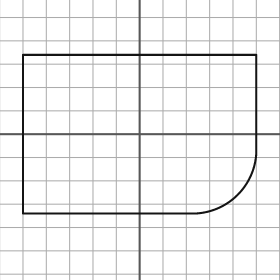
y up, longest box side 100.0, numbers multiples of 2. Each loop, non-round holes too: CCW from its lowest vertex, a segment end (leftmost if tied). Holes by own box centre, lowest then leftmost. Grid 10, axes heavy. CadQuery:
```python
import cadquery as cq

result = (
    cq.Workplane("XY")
    .moveTo(-50.0, -34.0)
    .lineTo(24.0, -34.0)
    .threePointArc((42.0, -26.0), (50.0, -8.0))
    .lineTo(50.0, 34.0)
    .lineTo(-50.0, 34.0)
    .close()
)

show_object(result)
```